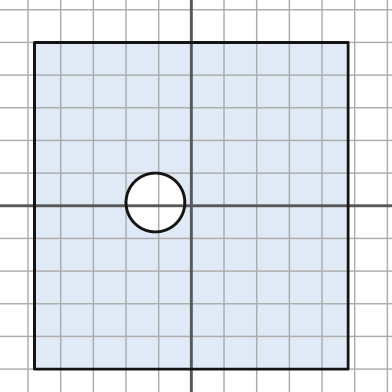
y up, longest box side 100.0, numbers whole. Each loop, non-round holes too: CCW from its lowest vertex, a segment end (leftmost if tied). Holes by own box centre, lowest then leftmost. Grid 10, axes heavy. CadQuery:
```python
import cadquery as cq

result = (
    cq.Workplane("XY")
    .moveTo(-48.0, -50.0)
    .lineTo(48.0, -50.0)
    .lineTo(48.0, 50.0)
    .lineTo(-48.0, 50.0)
    .close()
    .moveTo(-11.0, 1.0)
    .circle(9.0)
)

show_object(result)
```